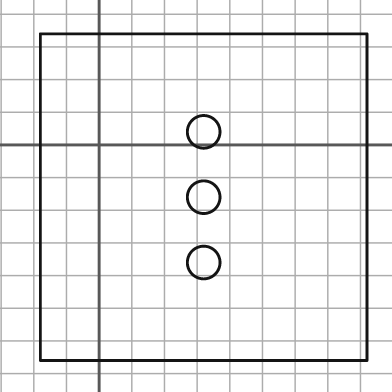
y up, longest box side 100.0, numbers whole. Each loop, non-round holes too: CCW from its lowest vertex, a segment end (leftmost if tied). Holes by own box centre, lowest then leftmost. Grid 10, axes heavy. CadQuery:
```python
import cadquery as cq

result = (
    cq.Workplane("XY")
    .moveTo(-18.0, -66.0)
    .lineTo(82.0, -66.0)
    .lineTo(82.0, 34.0)
    .lineTo(-18.0, 34.0)
    .close()
    .moveTo(32.0, -36.0)
    .circle(5.0)
    .moveTo(32.0, -16.0)
    .circle(5.0)
    .moveTo(32.0, 4.0)
    .circle(5.0)
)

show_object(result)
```